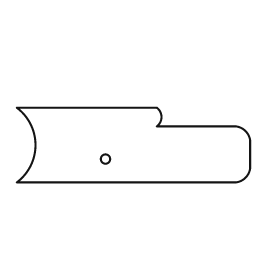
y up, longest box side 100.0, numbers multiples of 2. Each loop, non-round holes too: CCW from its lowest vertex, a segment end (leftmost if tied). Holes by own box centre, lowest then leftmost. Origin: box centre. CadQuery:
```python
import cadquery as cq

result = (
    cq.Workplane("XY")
    .moveTo(-50.0, -16.0)
    .lineTo(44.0, -16.0)
    .threePointArc((48.0, -14.0), (50.0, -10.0))
    .lineTo(50.0, 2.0)
    .threePointArc((48.0, 6.0), (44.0, 8.0))
    .lineTo(10.0, 8.0)
    .threePointArc((12.0, 12.0), (10.0, 16.0))
    .lineTo(-50.0, 16.0)
    .threePointArc((-42.0, 0.0), (-50.0, -16.0))
    .close()
    .moveTo(-12.0, -6.0)
    .circle(2.0)
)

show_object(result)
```